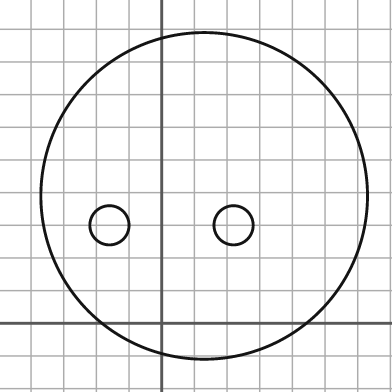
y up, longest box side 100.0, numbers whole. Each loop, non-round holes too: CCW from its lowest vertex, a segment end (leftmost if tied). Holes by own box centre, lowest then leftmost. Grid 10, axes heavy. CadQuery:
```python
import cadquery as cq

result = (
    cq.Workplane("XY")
    .moveTo(13.0, 39.0)
    .circle(50.0)
    .moveTo(-16.0, 30.0)
    .circle(6.0)
    .moveTo(22.0, 30.0)
    .circle(6.0)
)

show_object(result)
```